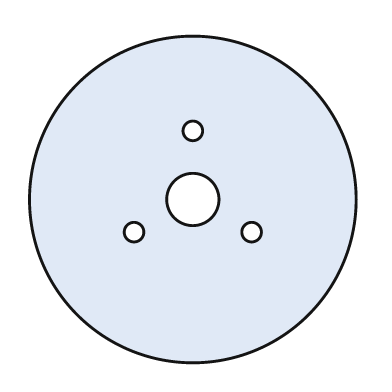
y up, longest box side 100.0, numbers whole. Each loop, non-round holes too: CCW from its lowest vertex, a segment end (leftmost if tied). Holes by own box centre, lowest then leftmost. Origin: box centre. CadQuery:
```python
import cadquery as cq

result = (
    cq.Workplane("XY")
    .moveTo(0.0, 0.0)
    .circle(50.0)
    .moveTo(-18.0, -10.0)
    .circle(3.0)
    .moveTo(18.0, -10.0)
    .circle(3.0)
    .moveTo(0.0, 0.0)
    .circle(8.0)
    .moveTo(0.0, 21.0)
    .circle(3.0)
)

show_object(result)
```